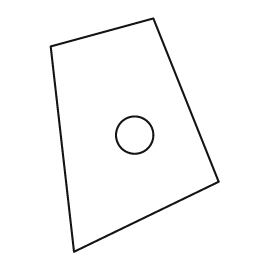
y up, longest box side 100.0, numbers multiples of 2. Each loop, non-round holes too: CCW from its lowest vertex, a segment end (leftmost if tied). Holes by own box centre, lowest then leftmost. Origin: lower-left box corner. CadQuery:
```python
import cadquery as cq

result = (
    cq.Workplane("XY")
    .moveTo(10.0, 0.0)
    .lineTo(72.0, 30.0)
    .lineTo(44.0, 100.0)
    .lineTo(0.0, 88.0)
    .close()
    .moveTo(36.0, 50.0)
    .circle(8.0)
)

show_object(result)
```